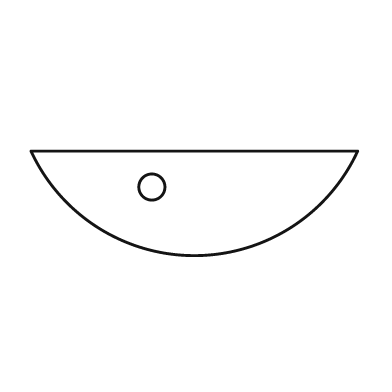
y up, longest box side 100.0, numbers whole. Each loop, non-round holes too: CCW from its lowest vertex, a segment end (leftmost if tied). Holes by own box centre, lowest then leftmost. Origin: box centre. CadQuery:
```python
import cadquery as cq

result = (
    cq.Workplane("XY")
    .moveTo(-50.0, 16.0)
    .threePointArc((0.0, -16.0), (50.0, 16.0))
    .close()
    .moveTo(-13.0, 5.0)
    .circle(4.0)
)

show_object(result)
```